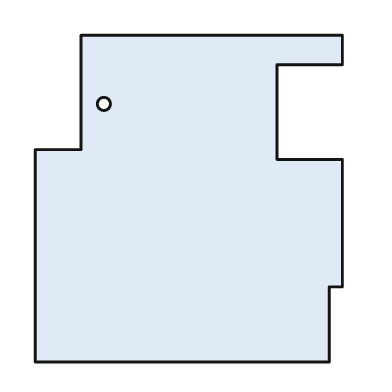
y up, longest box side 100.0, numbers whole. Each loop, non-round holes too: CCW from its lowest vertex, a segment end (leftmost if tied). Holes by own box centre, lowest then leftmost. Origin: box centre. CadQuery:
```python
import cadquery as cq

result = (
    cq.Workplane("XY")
    .moveTo(-47.0, -50.0)
    .lineTo(43.0, -50.0)
    .lineTo(43.0, -27.0)
    .lineTo(47.0, -27.0)
    .lineTo(47.0, 12.0)
    .lineTo(27.0, 12.0)
    .lineTo(27.0, 41.0)
    .lineTo(47.0, 41.0)
    .lineTo(47.0, 50.0)
    .lineTo(-33.0, 50.0)
    .lineTo(-33.0, 15.0)
    .lineTo(-47.0, 15.0)
    .close()
    .moveTo(-26.0, 29.0)
    .circle(2.0)
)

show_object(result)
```